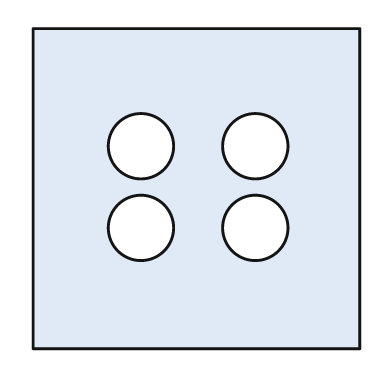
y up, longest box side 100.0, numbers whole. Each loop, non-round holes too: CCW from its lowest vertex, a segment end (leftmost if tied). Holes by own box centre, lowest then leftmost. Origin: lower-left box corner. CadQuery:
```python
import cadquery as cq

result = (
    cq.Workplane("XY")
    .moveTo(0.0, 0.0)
    .lineTo(100.0, 0.0)
    .lineTo(100.0, 98.0)
    .lineTo(0.0, 98.0)
    .close()
    .moveTo(33.0, 37.0)
    .circle(10.0)
    .moveTo(68.0, 37.0)
    .circle(10.0)
    .moveTo(33.0, 62.0)
    .circle(10.0)
    .moveTo(68.0, 62.0)
    .circle(10.0)
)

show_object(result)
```